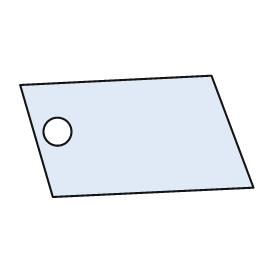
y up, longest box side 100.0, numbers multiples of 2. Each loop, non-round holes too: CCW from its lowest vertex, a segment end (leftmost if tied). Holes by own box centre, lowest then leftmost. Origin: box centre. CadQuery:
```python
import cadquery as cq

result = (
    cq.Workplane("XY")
    .moveTo(-36.0, -26.0)
    .lineTo(50.0, -22.0)
    .lineTo(32.0, 26.0)
    .lineTo(-50.0, 22.0)
    .close()
    .moveTo(-34.0, 2.0)
    .circle(6.0)
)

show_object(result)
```